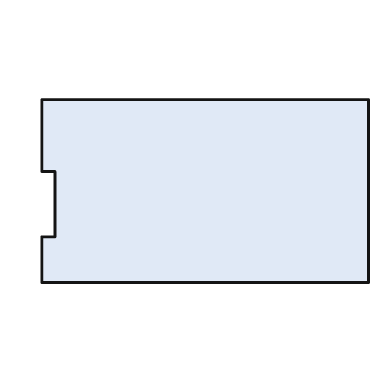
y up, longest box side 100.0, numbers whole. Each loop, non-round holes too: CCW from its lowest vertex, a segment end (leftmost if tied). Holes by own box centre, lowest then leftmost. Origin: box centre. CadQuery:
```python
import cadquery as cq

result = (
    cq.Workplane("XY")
    .moveTo(-50.0, -28.0)
    .lineTo(50.0, -28.0)
    .lineTo(50.0, 28.0)
    .lineTo(-50.0, 28.0)
    .lineTo(-50.0, 6.0)
    .lineTo(-46.0, 6.0)
    .lineTo(-46.0, -14.0)
    .lineTo(-50.0, -14.0)
    .close()
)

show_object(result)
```